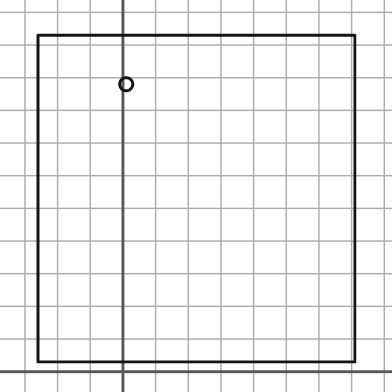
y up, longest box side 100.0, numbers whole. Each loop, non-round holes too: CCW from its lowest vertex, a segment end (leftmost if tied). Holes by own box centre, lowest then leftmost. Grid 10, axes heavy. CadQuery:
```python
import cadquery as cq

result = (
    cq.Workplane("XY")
    .moveTo(-26.0, 3.0)
    .lineTo(71.0, 3.0)
    .lineTo(71.0, 103.0)
    .lineTo(-26.0, 103.0)
    .close()
    .moveTo(1.0, 88.0)
    .circle(2.0)
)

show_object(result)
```